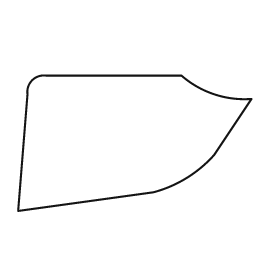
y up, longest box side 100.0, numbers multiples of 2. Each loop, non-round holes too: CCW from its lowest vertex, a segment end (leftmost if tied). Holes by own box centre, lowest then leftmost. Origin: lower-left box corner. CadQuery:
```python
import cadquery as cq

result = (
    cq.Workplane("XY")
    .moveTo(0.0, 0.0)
    .lineTo(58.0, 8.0)
    .threePointArc((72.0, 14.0), (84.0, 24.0))
    .lineTo(100.0, 48.0)
    .threePointArc((84.0, 50.0), (70.0, 58.0))
    .lineTo(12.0, 58.0)
    .threePointArc((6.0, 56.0), (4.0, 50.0))
    .close()
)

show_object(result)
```